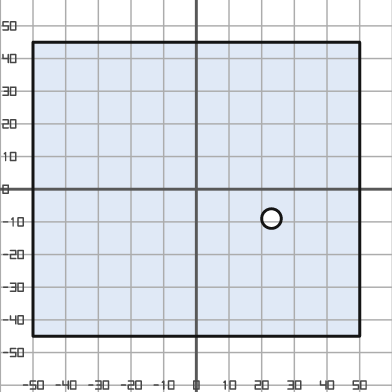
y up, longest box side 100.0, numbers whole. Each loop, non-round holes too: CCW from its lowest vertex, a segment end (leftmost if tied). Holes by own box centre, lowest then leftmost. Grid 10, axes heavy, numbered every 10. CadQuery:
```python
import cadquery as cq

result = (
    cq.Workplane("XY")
    .moveTo(-50.0, -45.0)
    .lineTo(50.0, -45.0)
    .lineTo(50.0, 45.0)
    .lineTo(-50.0, 45.0)
    .close()
    .moveTo(23.0, -9.0)
    .circle(3.0)
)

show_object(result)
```